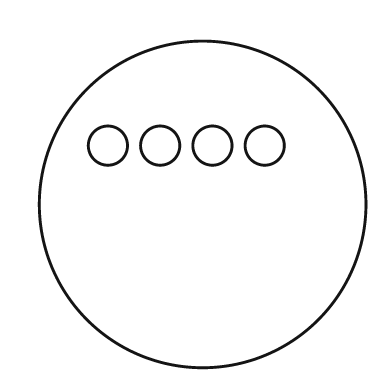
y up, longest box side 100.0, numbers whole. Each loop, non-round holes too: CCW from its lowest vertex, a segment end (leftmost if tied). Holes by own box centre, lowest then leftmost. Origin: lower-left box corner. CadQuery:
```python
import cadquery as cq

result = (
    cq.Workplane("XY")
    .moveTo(50.0, 50.0)
    .circle(50.0)
    .moveTo(21.0, 68.0)
    .circle(6.0)
    .moveTo(37.0, 68.0)
    .circle(6.0)
    .moveTo(53.0, 68.0)
    .circle(6.0)
    .moveTo(69.0, 68.0)
    .circle(6.0)
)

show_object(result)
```